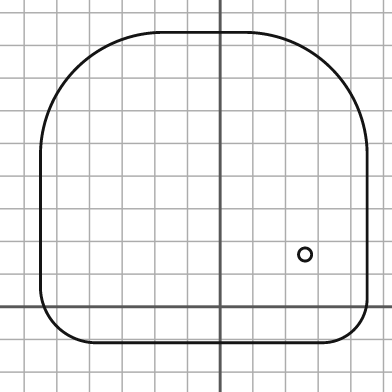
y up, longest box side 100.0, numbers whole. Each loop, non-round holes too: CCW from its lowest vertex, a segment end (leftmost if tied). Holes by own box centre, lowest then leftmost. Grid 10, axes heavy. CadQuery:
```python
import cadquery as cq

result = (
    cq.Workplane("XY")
    .moveTo(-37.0, -11.0)
    .lineTo(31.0, -11.0)
    .threePointArc((41.0, -7.0), (45.0, 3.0))
    .lineTo(45.0, 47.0)
    .threePointArc((34.0, 73.0), (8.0, 84.0))
    .lineTo(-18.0, 84.0)
    .threePointArc((-44.0, 73.0), (-55.0, 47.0))
    .lineTo(-55.0, 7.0)
    .threePointArc((-50.0, -6.0), (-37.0, -11.0))
    .close()
    .moveTo(26.0, 16.0)
    .circle(2.0)
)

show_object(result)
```